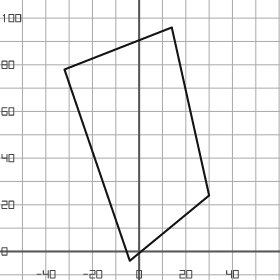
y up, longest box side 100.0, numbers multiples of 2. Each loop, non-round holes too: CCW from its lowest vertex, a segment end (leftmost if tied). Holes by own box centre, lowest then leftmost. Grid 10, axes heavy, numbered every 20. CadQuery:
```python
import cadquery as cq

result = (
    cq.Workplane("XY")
    .moveTo(-4.0, -4.0)
    .lineTo(30.0, 24.0)
    .lineTo(14.0, 96.0)
    .lineTo(-32.0, 78.0)
    .close()
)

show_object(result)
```